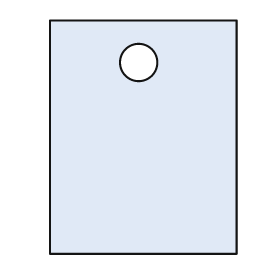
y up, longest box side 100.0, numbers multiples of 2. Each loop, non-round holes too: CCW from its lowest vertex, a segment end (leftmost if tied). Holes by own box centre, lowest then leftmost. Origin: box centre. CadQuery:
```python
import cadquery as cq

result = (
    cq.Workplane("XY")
    .moveTo(-40.0, -50.0)
    .lineTo(40.0, -50.0)
    .lineTo(40.0, 50.0)
    .lineTo(-40.0, 50.0)
    .close()
    .moveTo(-2.0, 32.0)
    .circle(8.0)
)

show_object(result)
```